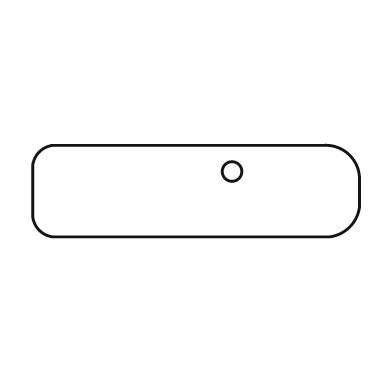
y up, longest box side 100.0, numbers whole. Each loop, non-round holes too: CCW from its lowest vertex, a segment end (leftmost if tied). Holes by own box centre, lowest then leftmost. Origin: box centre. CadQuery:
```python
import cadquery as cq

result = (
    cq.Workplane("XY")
    .moveTo(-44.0, -14.0)
    .lineTo(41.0, -14.0)
    .threePointArc((47.0, -11.0), (50.0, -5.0))
    .lineTo(50.0, 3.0)
    .threePointArc((47.0, 11.0), (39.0, 14.0))
    .lineTo(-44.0, 14.0)
    .threePointArc((-48.0, 12.0), (-50.0, 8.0))
    .lineTo(-50.0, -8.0)
    .threePointArc((-48.0, -12.0), (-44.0, -14.0))
    .close()
    .moveTo(11.0, 6.0)
    .circle(3.0)
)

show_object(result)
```